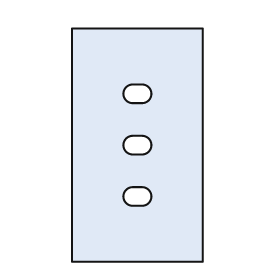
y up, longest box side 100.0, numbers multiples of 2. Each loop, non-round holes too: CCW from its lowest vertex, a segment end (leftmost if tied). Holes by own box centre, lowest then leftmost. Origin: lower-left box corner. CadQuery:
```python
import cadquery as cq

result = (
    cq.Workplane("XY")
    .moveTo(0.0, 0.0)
    .lineTo(56.0, 0.0)
    .lineTo(56.0, 100.0)
    .lineTo(0.0, 100.0)
    .close()
    .moveTo(26.0, 24.0)
    .lineTo(30.0, 24.0)
    .threePointArc((34.0, 28.0), (30.0, 32.0))
    .lineTo(26.0, 32.0)
    .threePointArc((22.0, 28.0), (26.0, 24.0))
    .close()
    .moveTo(26.0, 46.0)
    .lineTo(30.0, 46.0)
    .threePointArc((34.0, 50.0), (30.0, 54.0))
    .lineTo(26.0, 54.0)
    .threePointArc((22.0, 50.0), (26.0, 46.0))
    .close()
    .moveTo(26.0, 68.0)
    .lineTo(30.0, 68.0)
    .threePointArc((34.0, 72.0), (30.0, 76.0))
    .lineTo(26.0, 76.0)
    .threePointArc((22.0, 72.0), (26.0, 68.0))
    .close()
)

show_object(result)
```